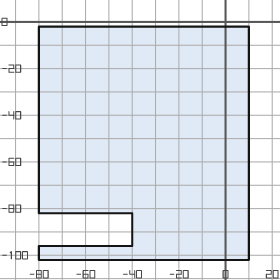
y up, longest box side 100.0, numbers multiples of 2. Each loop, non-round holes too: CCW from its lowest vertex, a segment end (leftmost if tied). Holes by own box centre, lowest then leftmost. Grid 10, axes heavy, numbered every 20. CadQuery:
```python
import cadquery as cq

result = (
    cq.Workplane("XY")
    .moveTo(-80.0, -102.0)
    .lineTo(10.0, -102.0)
    .lineTo(10.0, -2.0)
    .lineTo(-80.0, -2.0)
    .lineTo(-80.0, -82.0)
    .lineTo(-40.0, -82.0)
    .lineTo(-40.0, -96.0)
    .lineTo(-80.0, -96.0)
    .close()
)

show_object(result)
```